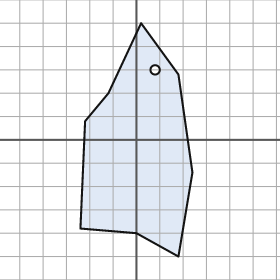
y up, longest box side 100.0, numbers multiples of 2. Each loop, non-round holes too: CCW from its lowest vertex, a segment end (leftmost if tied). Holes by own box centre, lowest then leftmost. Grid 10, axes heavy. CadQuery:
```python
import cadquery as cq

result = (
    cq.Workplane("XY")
    .moveTo(18.0, -50.0)
    .lineTo(24.0, -14.0)
    .lineTo(18.0, 28.0)
    .lineTo(2.0, 50.0)
    .lineTo(-12.0, 20.0)
    .lineTo(-22.0, 8.0)
    .lineTo(-24.0, -38.0)
    .lineTo(0.0, -40.0)
    .close()
    .moveTo(8.0, 30.0)
    .circle(2.0)
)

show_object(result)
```